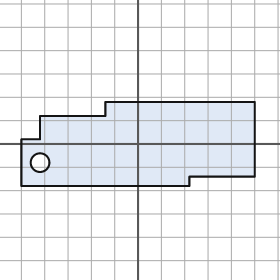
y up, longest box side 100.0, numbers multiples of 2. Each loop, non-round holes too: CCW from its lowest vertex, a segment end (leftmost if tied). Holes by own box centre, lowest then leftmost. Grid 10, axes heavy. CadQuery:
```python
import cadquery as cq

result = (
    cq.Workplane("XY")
    .moveTo(-50.0, -18.0)
    .lineTo(22.0, -18.0)
    .lineTo(22.0, -14.0)
    .lineTo(50.0, -14.0)
    .lineTo(50.0, 18.0)
    .lineTo(-14.0, 18.0)
    .lineTo(-14.0, 12.0)
    .lineTo(-42.0, 12.0)
    .lineTo(-42.0, 2.0)
    .lineTo(-50.0, 2.0)
    .close()
    .moveTo(-42.0, -8.0)
    .circle(4.0)
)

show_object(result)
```